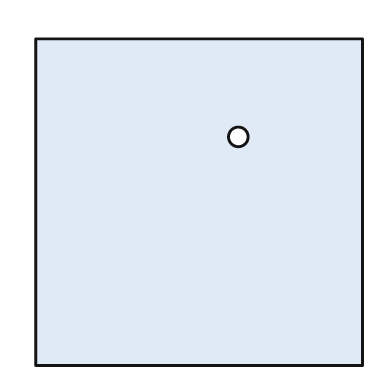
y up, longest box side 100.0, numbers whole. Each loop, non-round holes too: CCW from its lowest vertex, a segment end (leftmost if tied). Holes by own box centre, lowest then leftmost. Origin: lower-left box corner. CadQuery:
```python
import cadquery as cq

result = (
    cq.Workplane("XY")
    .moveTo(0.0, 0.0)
    .lineTo(100.0, 0.0)
    .lineTo(100.0, 100.0)
    .lineTo(0.0, 100.0)
    .close()
    .moveTo(62.0, 70.0)
    .circle(3.0)
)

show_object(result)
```